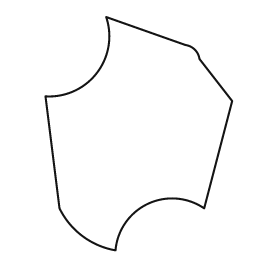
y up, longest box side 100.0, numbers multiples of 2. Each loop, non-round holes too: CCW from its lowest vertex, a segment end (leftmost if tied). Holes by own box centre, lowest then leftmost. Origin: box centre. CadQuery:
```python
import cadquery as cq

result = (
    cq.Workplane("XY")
    .moveTo(-10.0, -50.0)
    .threePointArc((4.0, -30.0), (28.0, -32.0))
    .lineTo(40.0, 14.0)
    .lineTo(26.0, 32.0)
    .threePointArc((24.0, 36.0), (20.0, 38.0))
    .lineTo(-14.0, 50.0)
    .threePointArc((-18.0, 26.0), (-40.0, 16.0))
    .lineTo(-34.0, -32.0)
    .threePointArc((-24.0, -44.0), (-10.0, -50.0))
    .close()
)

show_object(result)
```